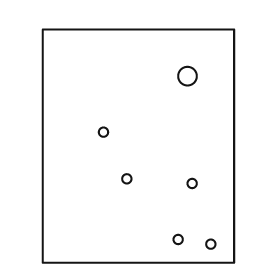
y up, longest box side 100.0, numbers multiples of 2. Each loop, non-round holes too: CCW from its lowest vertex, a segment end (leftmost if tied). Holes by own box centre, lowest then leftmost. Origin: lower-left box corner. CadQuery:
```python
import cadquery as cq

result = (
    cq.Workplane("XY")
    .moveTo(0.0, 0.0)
    .lineTo(82.0, 0.0)
    .lineTo(82.0, 100.0)
    .lineTo(0.0, 100.0)
    .close()
    .moveTo(72.0, 8.0)
    .circle(2.0)
    .moveTo(58.0, 10.0)
    .circle(2.0)
    .moveTo(64.0, 34.0)
    .circle(2.0)
    .moveTo(36.0, 36.0)
    .circle(2.0)
    .moveTo(26.0, 56.0)
    .circle(2.0)
    .moveTo(62.0, 80.0)
    .circle(4.0)
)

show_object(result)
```